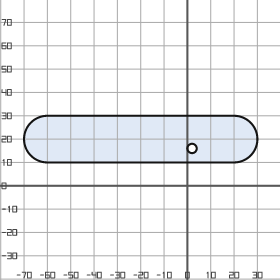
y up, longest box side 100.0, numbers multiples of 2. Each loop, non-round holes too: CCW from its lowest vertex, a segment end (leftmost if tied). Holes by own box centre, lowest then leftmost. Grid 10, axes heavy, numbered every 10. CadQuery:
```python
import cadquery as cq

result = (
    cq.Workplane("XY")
    .moveTo(-60.0, 10.0)
    .lineTo(20.0, 10.0)
    .threePointArc((30.0, 20.0), (20.0, 30.0))
    .lineTo(-60.0, 30.0)
    .threePointArc((-70.0, 20.0), (-60.0, 10.0))
    .close()
    .moveTo(2.0, 16.0)
    .circle(2.0)
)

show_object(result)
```